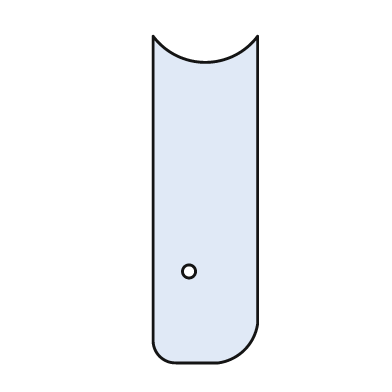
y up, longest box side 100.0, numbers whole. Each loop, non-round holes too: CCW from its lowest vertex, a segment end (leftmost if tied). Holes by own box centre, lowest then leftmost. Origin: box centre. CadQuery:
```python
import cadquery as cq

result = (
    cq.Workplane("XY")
    .moveTo(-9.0, -50.0)
    .lineTo(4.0, -50.0)
    .threePointArc((12.0, -46.0), (16.0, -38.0))
    .lineTo(16.0, 50.0)
    .threePointArc((0.0, 42.0), (-16.0, 50.0))
    .lineTo(-16.0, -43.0)
    .threePointArc((-14.0, -48.0), (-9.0, -50.0))
    .close()
    .moveTo(-5.0, -22.0)
    .circle(2.0)
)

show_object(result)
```